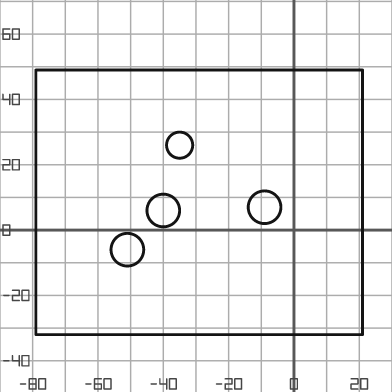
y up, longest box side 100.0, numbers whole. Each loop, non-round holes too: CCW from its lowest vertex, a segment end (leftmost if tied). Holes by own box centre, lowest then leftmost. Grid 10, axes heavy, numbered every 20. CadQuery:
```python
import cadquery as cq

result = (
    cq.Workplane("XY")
    .moveTo(-79.0, -32.0)
    .lineTo(21.0, -32.0)
    .lineTo(21.0, 49.0)
    .lineTo(-79.0, 49.0)
    .close()
    .moveTo(-51.0, -6.0)
    .circle(5.0)
    .moveTo(-40.0, 6.0)
    .circle(5.0)
    .moveTo(-9.0, 7.0)
    .circle(5.0)
    .moveTo(-35.0, 26.0)
    .circle(4.0)
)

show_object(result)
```